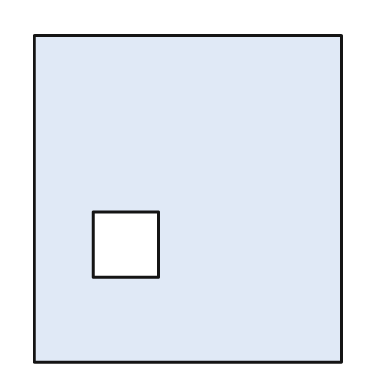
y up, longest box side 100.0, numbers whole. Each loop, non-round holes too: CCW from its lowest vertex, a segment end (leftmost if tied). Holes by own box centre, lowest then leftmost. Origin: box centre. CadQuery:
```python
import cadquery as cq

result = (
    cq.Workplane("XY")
    .moveTo(-47.0, -50.0)
    .lineTo(47.0, -50.0)
    .lineTo(47.0, 50.0)
    .lineTo(-47.0, 50.0)
    .close()
    .moveTo(-29.0, -24.0)
    .lineTo(-9.0, -24.0)
    .lineTo(-9.0, -4.0)
    .lineTo(-29.0, -4.0)
    .close()
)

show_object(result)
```